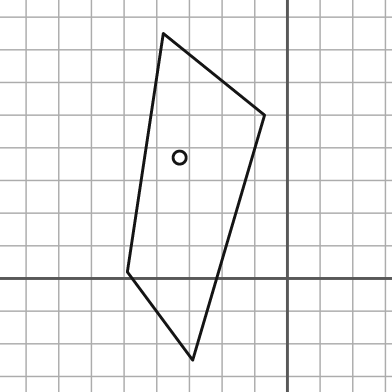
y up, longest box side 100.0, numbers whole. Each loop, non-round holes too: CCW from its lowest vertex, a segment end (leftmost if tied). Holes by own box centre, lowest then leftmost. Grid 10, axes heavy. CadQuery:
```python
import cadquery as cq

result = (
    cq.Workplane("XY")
    .moveTo(-29.0, -25.0)
    .lineTo(-7.0, 50.0)
    .lineTo(-38.0, 75.0)
    .lineTo(-49.0, 2.0)
    .close()
    .moveTo(-33.0, 37.0)
    .circle(2.0)
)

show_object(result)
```